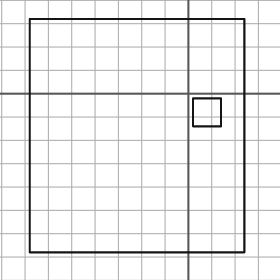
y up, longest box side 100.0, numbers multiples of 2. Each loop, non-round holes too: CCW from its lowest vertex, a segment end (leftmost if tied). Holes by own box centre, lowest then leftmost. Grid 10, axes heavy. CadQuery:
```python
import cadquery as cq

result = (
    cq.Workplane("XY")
    .moveTo(-68.0, -68.0)
    .lineTo(24.0, -68.0)
    .lineTo(24.0, 32.0)
    .lineTo(-68.0, 32.0)
    .close()
    .moveTo(2.0, -14.0)
    .lineTo(14.0, -14.0)
    .lineTo(14.0, -2.0)
    .lineTo(2.0, -2.0)
    .close()
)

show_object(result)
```